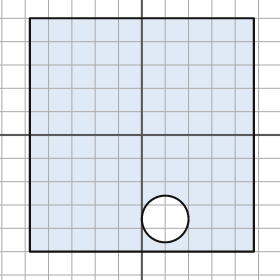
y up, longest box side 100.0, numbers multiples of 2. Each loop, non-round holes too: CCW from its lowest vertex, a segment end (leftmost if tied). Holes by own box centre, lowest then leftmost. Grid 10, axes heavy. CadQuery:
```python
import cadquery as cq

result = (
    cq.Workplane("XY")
    .moveTo(-48.0, -50.0)
    .lineTo(48.0, -50.0)
    .lineTo(48.0, 50.0)
    .lineTo(-48.0, 50.0)
    .close()
    .moveTo(10.0, -36.0)
    .circle(10.0)
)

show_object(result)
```